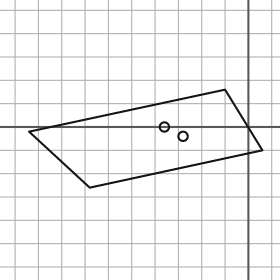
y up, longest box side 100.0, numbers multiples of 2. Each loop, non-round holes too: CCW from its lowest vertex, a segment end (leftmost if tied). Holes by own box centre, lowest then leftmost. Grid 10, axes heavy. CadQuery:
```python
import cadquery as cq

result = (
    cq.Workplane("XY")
    .moveTo(-68.0, -26.0)
    .lineTo(6.0, -10.0)
    .lineTo(-10.0, 16.0)
    .lineTo(-94.0, -2.0)
    .close()
    .moveTo(-28.0, -4.0)
    .circle(2.0)
    .moveTo(-36.0, 0.0)
    .circle(2.0)
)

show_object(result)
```